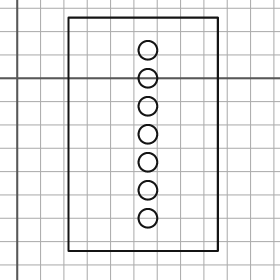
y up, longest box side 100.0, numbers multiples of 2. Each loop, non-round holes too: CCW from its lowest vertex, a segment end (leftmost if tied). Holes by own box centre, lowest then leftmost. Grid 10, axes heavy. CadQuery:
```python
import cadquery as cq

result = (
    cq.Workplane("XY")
    .moveTo(22.0, -74.0)
    .lineTo(86.0, -74.0)
    .lineTo(86.0, 26.0)
    .lineTo(22.0, 26.0)
    .close()
    .moveTo(56.0, -60.0)
    .circle(4.0)
    .moveTo(56.0, -48.0)
    .circle(4.0)
    .moveTo(56.0, -36.0)
    .circle(4.0)
    .moveTo(56.0, -24.0)
    .circle(4.0)
    .moveTo(56.0, -12.0)
    .circle(4.0)
    .moveTo(56.0, 0.0)
    .circle(4.0)
    .moveTo(56.0, 12.0)
    .circle(4.0)
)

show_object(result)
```